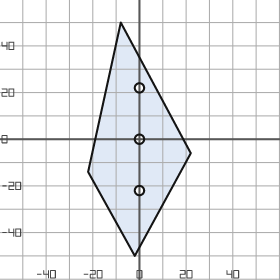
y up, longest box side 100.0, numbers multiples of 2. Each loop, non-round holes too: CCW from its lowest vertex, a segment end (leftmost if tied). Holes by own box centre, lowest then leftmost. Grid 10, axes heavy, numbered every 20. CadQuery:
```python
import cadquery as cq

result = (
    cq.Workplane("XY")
    .moveTo(-2.0, -50.0)
    .lineTo(22.0, -6.0)
    .lineTo(-8.0, 50.0)
    .lineTo(-22.0, -14.0)
    .close()
    .moveTo(0.0, -22.0)
    .circle(2.0)
    .moveTo(0.0, 0.0)
    .circle(2.0)
    .moveTo(0.0, 22.0)
    .circle(2.0)
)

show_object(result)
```